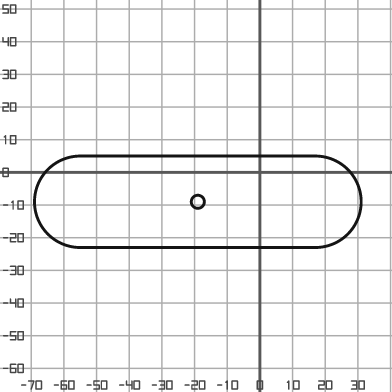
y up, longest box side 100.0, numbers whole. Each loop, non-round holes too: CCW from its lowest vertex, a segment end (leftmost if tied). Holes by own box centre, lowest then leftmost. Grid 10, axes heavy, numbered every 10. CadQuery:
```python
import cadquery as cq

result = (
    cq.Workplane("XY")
    .moveTo(-55.0, -23.0)
    .lineTo(17.0, -23.0)
    .threePointArc((31.0, -9.0), (17.0, 5.0))
    .lineTo(-55.0, 5.0)
    .threePointArc((-69.0, -9.0), (-55.0, -23.0))
    .close()
    .moveTo(-19.0, -9.0)
    .circle(2.0)
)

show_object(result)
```